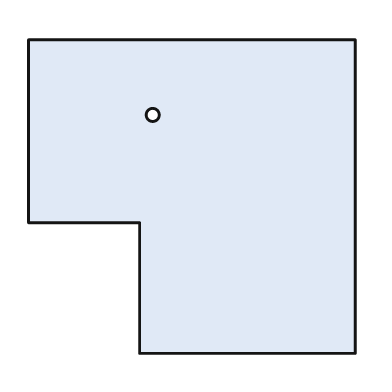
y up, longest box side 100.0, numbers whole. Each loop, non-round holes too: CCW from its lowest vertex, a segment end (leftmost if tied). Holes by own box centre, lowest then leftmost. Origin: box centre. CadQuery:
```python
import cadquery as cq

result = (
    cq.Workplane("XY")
    .moveTo(-16.0, -48.0)
    .lineTo(50.0, -48.0)
    .lineTo(50.0, 48.0)
    .lineTo(-50.0, 48.0)
    .lineTo(-50.0, -8.0)
    .lineTo(-16.0, -8.0)
    .close()
    .moveTo(-12.0, 25.0)
    .circle(2.0)
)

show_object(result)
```